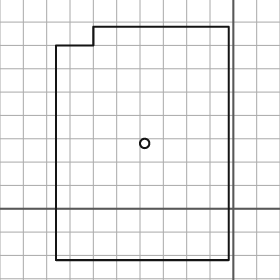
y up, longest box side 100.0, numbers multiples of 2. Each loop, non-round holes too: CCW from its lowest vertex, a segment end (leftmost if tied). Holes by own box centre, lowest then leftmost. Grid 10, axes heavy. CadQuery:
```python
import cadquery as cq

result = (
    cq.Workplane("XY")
    .moveTo(-76.0, -22.0)
    .lineTo(-2.0, -22.0)
    .lineTo(-2.0, 78.0)
    .lineTo(-60.0, 78.0)
    .lineTo(-60.0, 70.0)
    .lineTo(-76.0, 70.0)
    .close()
    .moveTo(-38.0, 28.0)
    .circle(2.0)
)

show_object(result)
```